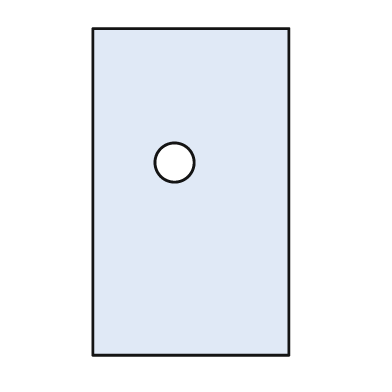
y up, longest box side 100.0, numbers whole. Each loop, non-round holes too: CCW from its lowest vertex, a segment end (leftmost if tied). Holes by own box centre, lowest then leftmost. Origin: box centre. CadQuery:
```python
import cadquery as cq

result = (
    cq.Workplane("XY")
    .moveTo(-30.0, -50.0)
    .lineTo(30.0, -50.0)
    .lineTo(30.0, 50.0)
    .lineTo(-30.0, 50.0)
    .close()
    .moveTo(-5.0, 9.0)
    .circle(6.0)
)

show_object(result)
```